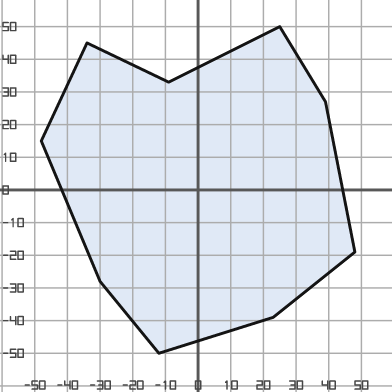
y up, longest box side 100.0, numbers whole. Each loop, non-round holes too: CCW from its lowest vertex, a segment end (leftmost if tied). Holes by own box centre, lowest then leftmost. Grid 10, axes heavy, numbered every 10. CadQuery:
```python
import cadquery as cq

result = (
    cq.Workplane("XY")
    .moveTo(-12.0, -50.0)
    .lineTo(23.0, -39.0)
    .lineTo(48.0, -19.0)
    .lineTo(39.0, 27.0)
    .lineTo(25.0, 50.0)
    .lineTo(-9.0, 33.0)
    .lineTo(-34.0, 45.0)
    .lineTo(-48.0, 15.0)
    .lineTo(-30.0, -28.0)
    .close()
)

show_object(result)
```